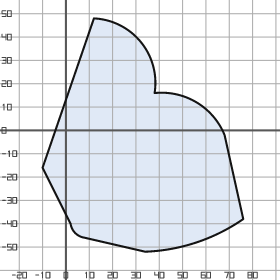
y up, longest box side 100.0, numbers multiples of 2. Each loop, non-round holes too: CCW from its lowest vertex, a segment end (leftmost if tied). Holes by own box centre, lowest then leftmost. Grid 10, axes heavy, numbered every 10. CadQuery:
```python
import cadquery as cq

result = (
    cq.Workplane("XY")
    .moveTo(34.0, -52.0)
    .threePointArc((56.0, -48.0), (76.0, -38.0))
    .lineTo(68.0, -2.0)
    .threePointArc((56.0, 12.0), (38.0, 16.0))
    .threePointArc((32.0, 38.0), (12.0, 48.0))
    .lineTo(-10.0, -16.0)
    .lineTo(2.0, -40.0)
    .threePointArc((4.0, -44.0), (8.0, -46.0))
    .close()
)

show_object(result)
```